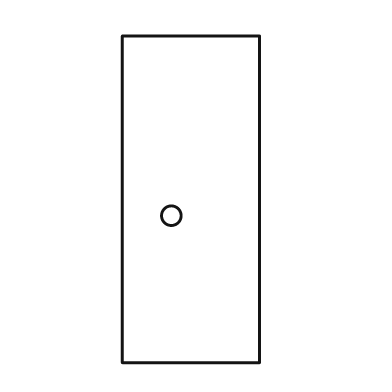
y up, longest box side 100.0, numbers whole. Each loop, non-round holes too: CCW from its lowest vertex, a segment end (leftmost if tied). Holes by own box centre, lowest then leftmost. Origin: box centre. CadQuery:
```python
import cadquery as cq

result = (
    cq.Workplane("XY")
    .moveTo(-21.0, -50.0)
    .lineTo(21.0, -50.0)
    .lineTo(21.0, 50.0)
    .lineTo(-21.0, 50.0)
    .close()
    .moveTo(-6.0, -5.0)
    .circle(3.0)
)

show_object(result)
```